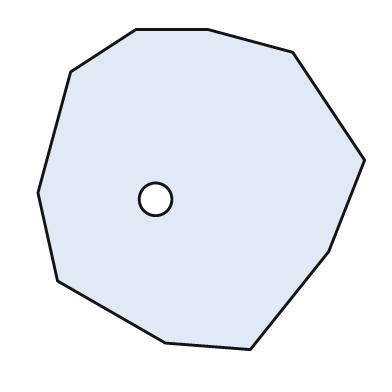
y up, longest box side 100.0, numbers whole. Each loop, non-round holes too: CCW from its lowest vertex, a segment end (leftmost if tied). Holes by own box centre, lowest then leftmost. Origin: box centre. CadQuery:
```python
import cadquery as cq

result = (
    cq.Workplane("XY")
    .moveTo(15.0, -49.0)
    .lineTo(39.0, -19.0)
    .lineTo(50.0, 9.0)
    .lineTo(28.0, 42.0)
    .lineTo(2.0, 49.0)
    .lineTo(-20.0, 49.0)
    .lineTo(-40.0, 36.0)
    .lineTo(-50.0, -1.0)
    .lineTo(-44.0, -28.0)
    .lineTo(-11.0, -47.0)
    .close()
    .moveTo(-14.0, -3.0)
    .circle(5.0)
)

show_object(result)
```